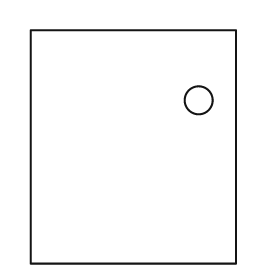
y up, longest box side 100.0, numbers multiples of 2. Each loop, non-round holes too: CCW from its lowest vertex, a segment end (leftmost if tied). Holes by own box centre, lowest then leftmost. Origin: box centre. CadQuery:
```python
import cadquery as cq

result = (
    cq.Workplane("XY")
    .moveTo(-44.0, -50.0)
    .lineTo(44.0, -50.0)
    .lineTo(44.0, 50.0)
    .lineTo(-44.0, 50.0)
    .close()
    .moveTo(28.0, 20.0)
    .circle(6.0)
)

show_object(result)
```